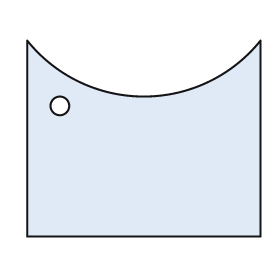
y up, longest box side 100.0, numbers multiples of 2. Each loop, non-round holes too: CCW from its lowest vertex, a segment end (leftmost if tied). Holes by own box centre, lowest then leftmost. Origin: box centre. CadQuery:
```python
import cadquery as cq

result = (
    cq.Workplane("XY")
    .moveTo(-50.0, -42.0)
    .lineTo(50.0, -42.0)
    .lineTo(50.0, 42.0)
    .threePointArc((0.0, 18.0), (-50.0, 42.0))
    .close()
    .moveTo(-36.0, 14.0)
    .circle(4.0)
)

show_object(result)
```